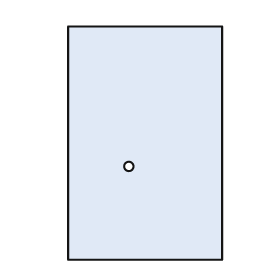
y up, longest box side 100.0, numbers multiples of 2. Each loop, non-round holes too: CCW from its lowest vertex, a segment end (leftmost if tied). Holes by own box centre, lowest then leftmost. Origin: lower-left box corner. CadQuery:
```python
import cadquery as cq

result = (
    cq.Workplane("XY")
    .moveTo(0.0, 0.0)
    .lineTo(66.0, 0.0)
    .lineTo(66.0, 100.0)
    .lineTo(0.0, 100.0)
    .close()
    .moveTo(26.0, 40.0)
    .circle(2.0)
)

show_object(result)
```